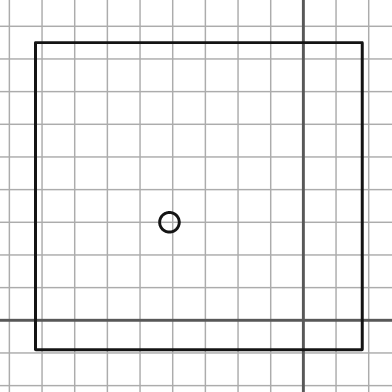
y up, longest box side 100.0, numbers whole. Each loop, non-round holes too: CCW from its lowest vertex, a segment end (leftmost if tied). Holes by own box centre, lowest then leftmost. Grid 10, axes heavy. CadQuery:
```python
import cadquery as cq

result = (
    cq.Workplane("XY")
    .moveTo(-82.0, -9.0)
    .lineTo(18.0, -9.0)
    .lineTo(18.0, 85.0)
    .lineTo(-82.0, 85.0)
    .close()
    .moveTo(-41.0, 30.0)
    .circle(3.0)
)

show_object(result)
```